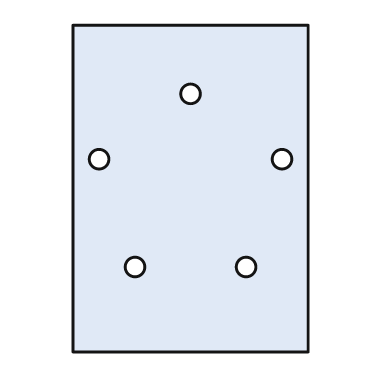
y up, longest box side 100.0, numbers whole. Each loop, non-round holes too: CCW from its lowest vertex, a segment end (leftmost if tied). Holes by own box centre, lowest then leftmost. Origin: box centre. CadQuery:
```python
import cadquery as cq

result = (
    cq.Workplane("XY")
    .moveTo(-36.0, -50.0)
    .lineTo(36.0, -50.0)
    .lineTo(36.0, 50.0)
    .lineTo(-36.0, 50.0)
    .close()
    .moveTo(-17.0, -24.0)
    .circle(3.0)
    .moveTo(17.0, -24.0)
    .circle(3.0)
    .moveTo(-28.0, 9.0)
    .circle(3.0)
    .moveTo(28.0, 9.0)
    .circle(3.0)
    .moveTo(0.0, 29.0)
    .circle(3.0)
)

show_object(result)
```